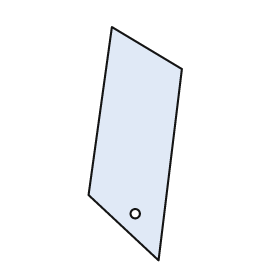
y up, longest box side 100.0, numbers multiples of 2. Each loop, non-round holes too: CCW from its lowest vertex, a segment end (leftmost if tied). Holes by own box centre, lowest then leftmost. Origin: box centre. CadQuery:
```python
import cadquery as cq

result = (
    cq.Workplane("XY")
    .moveTo(10.0, -50.0)
    .lineTo(20.0, 32.0)
    .lineTo(-10.0, 50.0)
    .lineTo(-20.0, -22.0)
    .close()
    .moveTo(0.0, -30.0)
    .circle(2.0)
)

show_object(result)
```